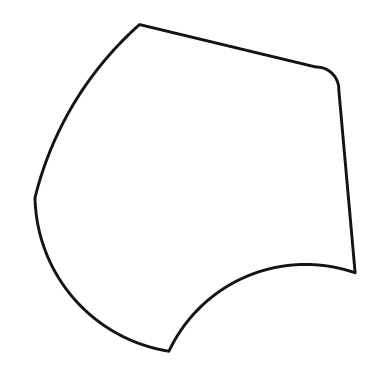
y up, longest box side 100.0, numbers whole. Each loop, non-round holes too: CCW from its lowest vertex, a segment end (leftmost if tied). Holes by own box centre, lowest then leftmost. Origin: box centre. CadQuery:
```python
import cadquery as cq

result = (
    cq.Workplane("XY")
    .moveTo(-8.0, -50.0)
    .threePointArc((16.0, -27.0), (49.0, -26.0))
    .lineTo(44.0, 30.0)
    .threePointArc((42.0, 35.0), (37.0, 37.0))
    .lineTo(-17.0, 50.0)
    .threePointArc((-37.0, 26.0), (-49.0, -3.0))
    .threePointArc((-37.0, -34.0), (-8.0, -50.0))
    .close()
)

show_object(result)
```